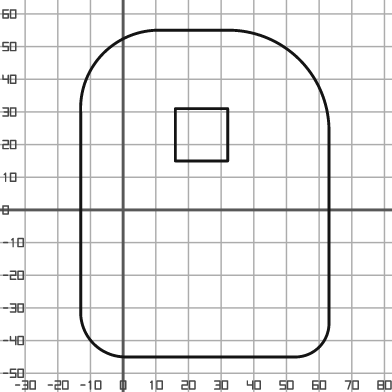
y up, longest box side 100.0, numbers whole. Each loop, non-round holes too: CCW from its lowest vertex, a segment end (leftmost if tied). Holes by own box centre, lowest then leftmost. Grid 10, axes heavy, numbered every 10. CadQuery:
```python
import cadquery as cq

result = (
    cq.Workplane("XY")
    .moveTo(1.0, -45.0)
    .lineTo(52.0, -45.0)
    .threePointArc((60.0, -42.0), (63.0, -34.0))
    .lineTo(63.0, 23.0)
    .threePointArc((54.0, 46.0), (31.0, 55.0))
    .lineTo(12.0, 55.0)
    .threePointArc((-6.0, 48.0), (-13.0, 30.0))
    .lineTo(-13.0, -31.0)
    .threePointArc((-9.0, -41.0), (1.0, -45.0))
    .close()
    .moveTo(16.0, 15.0)
    .lineTo(32.0, 15.0)
    .lineTo(32.0, 31.0)
    .lineTo(16.0, 31.0)
    .close()
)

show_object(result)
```